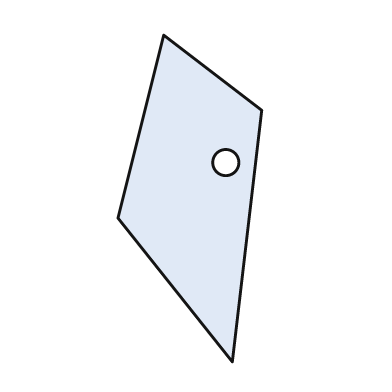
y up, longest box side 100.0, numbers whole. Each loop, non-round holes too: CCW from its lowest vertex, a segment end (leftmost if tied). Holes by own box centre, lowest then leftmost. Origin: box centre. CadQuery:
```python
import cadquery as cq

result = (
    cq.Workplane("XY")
    .moveTo(13.0, -50.0)
    .lineTo(22.0, 27.0)
    .lineTo(-8.0, 50.0)
    .lineTo(-22.0, -6.0)
    .close()
    .moveTo(11.0, 11.0)
    .circle(4.0)
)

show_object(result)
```